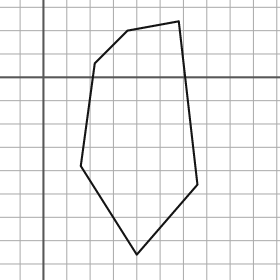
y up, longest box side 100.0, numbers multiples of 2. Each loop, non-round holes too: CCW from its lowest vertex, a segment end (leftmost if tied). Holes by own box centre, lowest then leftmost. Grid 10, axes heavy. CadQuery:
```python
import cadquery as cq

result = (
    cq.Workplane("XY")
    .moveTo(40.0, -76.0)
    .lineTo(66.0, -46.0)
    .lineTo(58.0, 24.0)
    .lineTo(36.0, 20.0)
    .lineTo(22.0, 6.0)
    .lineTo(16.0, -38.0)
    .close()
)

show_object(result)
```